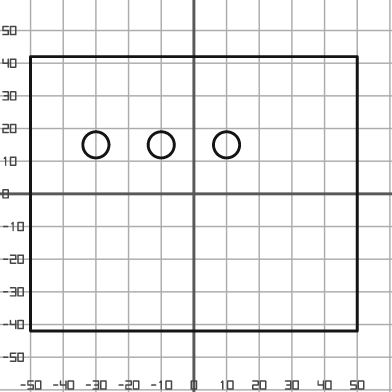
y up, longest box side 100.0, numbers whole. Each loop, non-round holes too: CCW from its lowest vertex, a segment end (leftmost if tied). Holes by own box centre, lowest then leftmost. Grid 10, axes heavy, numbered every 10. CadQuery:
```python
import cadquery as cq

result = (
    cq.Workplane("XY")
    .moveTo(-50.0, -42.0)
    .lineTo(50.0, -42.0)
    .lineTo(50.0, 42.0)
    .lineTo(-50.0, 42.0)
    .close()
    .moveTo(-30.0, 15.0)
    .circle(4.0)
    .moveTo(-10.0, 15.0)
    .circle(4.0)
    .moveTo(10.0, 15.0)
    .circle(4.0)
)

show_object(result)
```